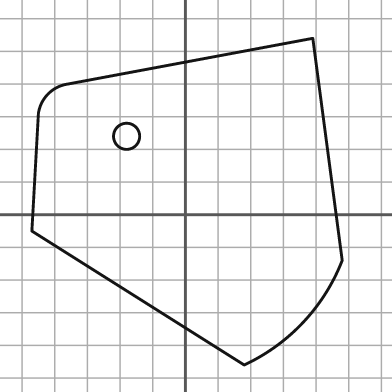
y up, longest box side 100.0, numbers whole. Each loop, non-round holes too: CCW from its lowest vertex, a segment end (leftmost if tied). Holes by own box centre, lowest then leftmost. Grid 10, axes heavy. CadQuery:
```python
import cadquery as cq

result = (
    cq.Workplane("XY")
    .moveTo(18.0, -46.0)
    .threePointArc((36.0, -33.0), (48.0, -14.0))
    .lineTo(39.0, 54.0)
    .lineTo(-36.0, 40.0)
    .threePointArc((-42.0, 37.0), (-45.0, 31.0))
    .lineTo(-47.0, -5.0)
    .close()
    .moveTo(-18.0, 24.0)
    .circle(4.0)
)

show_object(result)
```